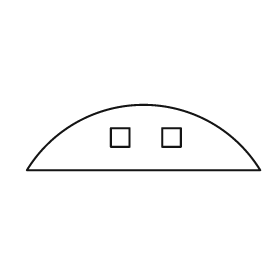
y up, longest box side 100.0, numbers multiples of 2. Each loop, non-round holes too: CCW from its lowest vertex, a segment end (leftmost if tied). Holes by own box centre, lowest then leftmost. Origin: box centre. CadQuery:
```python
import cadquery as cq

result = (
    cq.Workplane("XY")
    .moveTo(-50.0, -14.0)
    .lineTo(50.0, -14.0)
    .threePointArc((0.0, 14.0), (-50.0, -14.0))
    .close()
    .moveTo(-14.0, -4.0)
    .lineTo(-6.0, -4.0)
    .lineTo(-6.0, 4.0)
    .lineTo(-14.0, 4.0)
    .close()
    .moveTo(8.0, -4.0)
    .lineTo(16.0, -4.0)
    .lineTo(16.0, 4.0)
    .lineTo(8.0, 4.0)
    .close()
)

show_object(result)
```